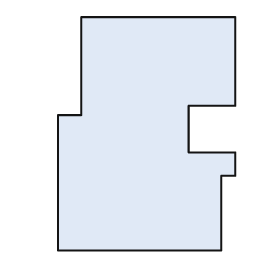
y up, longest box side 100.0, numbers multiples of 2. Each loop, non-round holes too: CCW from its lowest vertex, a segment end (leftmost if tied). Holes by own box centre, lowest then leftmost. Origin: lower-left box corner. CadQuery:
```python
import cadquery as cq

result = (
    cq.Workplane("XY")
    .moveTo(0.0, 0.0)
    .lineTo(70.0, 0.0)
    .lineTo(70.0, 32.0)
    .lineTo(76.0, 32.0)
    .lineTo(76.0, 42.0)
    .lineTo(56.0, 42.0)
    .lineTo(56.0, 62.0)
    .lineTo(76.0, 62.0)
    .lineTo(76.0, 100.0)
    .lineTo(10.0, 100.0)
    .lineTo(10.0, 58.0)
    .lineTo(0.0, 58.0)
    .close()
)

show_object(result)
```